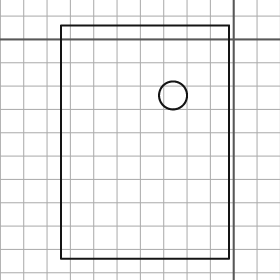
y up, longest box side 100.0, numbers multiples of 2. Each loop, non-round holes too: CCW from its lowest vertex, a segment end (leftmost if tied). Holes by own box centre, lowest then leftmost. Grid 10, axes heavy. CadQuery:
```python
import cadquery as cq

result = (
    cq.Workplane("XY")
    .moveTo(-74.0, -94.0)
    .lineTo(-2.0, -94.0)
    .lineTo(-2.0, 6.0)
    .lineTo(-74.0, 6.0)
    .close()
    .moveTo(-26.0, -24.0)
    .circle(6.0)
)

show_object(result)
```